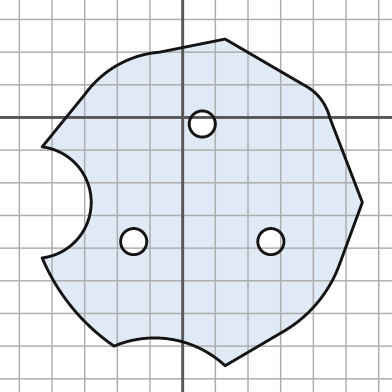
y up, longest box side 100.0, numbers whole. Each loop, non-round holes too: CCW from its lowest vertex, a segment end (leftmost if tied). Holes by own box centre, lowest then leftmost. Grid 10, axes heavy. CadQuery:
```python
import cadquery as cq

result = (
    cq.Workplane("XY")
    .moveTo(13.0, -76.0)
    .lineTo(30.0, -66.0)
    .threePointArc((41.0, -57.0), (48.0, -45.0))
    .lineTo(55.0, -26.0)
    .lineTo(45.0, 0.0)
    .threePointArc((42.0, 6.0), (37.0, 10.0))
    .lineTo(13.0, 24.0)
    .lineTo(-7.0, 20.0)
    .threePointArc((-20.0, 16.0), (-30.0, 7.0))
    .lineTo(-43.0, -9.0)
    .threePointArc((-28.0, -26.0), (-43.0, -43.0))
    .threePointArc((-34.0, -58.0), (-21.0, -70.0))
    .threePointArc((-3.0, -68.0), (13.0, -76.0))
    .close()
    .moveTo(-15.0, -38.0)
    .circle(4.0)
    .moveTo(27.0, -38.0)
    .circle(4.0)
    .moveTo(6.0, -2.0)
    .circle(4.0)
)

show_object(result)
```